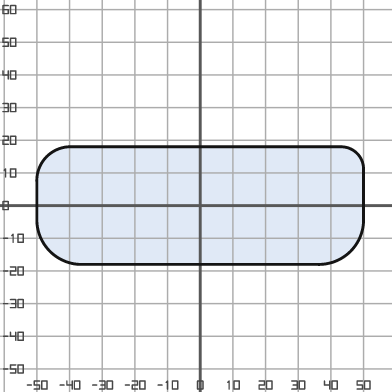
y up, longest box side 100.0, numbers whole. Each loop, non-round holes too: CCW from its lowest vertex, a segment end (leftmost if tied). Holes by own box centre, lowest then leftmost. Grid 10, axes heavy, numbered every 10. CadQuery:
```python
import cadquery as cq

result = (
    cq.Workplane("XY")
    .moveTo(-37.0, -18.0)
    .lineTo(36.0, -18.0)
    .threePointArc((46.0, -14.0), (50.0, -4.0))
    .lineTo(50.0, 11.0)
    .threePointArc((48.0, 16.0), (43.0, 18.0))
    .lineTo(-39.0, 18.0)
    .threePointArc((-47.0, 15.0), (-50.0, 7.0))
    .lineTo(-50.0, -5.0)
    .threePointArc((-46.0, -14.0), (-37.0, -18.0))
    .close()
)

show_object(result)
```